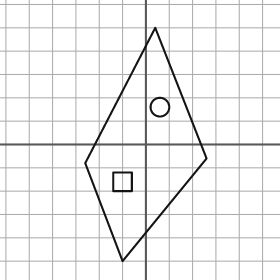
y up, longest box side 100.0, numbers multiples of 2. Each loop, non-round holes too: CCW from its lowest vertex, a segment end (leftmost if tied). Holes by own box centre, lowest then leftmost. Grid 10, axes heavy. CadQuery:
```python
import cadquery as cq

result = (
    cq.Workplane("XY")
    .moveTo(-10.0, -50.0)
    .lineTo(26.0, -6.0)
    .lineTo(4.0, 50.0)
    .lineTo(-26.0, -8.0)
    .close()
    .moveTo(-14.0, -20.0)
    .lineTo(-6.0, -20.0)
    .lineTo(-6.0, -12.0)
    .lineTo(-14.0, -12.0)
    .close()
    .moveTo(6.0, 16.0)
    .circle(4.0)
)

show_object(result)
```